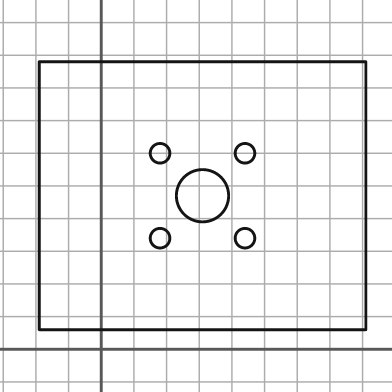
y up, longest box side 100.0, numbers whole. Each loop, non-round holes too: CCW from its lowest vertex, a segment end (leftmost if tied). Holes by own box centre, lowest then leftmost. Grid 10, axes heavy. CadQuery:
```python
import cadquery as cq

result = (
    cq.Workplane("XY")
    .moveTo(-19.0, 6.0)
    .lineTo(81.0, 6.0)
    .lineTo(81.0, 88.0)
    .lineTo(-19.0, 88.0)
    .close()
    .moveTo(18.0, 34.0)
    .circle(3.0)
    .moveTo(44.0, 34.0)
    .circle(3.0)
    .moveTo(31.0, 47.0)
    .circle(8.0)
    .moveTo(18.0, 60.0)
    .circle(3.0)
    .moveTo(44.0, 60.0)
    .circle(3.0)
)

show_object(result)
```